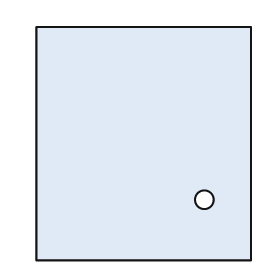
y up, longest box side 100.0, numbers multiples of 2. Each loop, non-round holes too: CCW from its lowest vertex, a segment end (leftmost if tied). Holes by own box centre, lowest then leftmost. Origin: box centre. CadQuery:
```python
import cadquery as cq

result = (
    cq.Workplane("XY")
    .moveTo(-46.0, -50.0)
    .lineTo(46.0, -50.0)
    .lineTo(46.0, 50.0)
    .lineTo(-46.0, 50.0)
    .close()
    .moveTo(26.0, -24.0)
    .circle(4.0)
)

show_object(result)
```